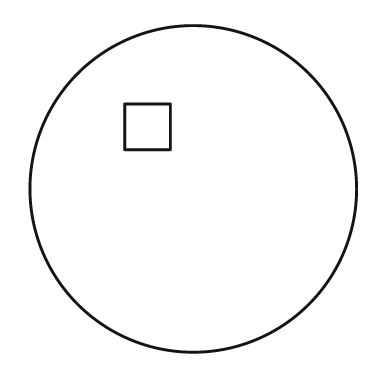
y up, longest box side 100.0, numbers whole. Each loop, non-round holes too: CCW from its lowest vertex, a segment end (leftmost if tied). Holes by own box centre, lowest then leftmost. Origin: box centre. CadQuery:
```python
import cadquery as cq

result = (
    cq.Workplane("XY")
    .moveTo(0.0, 0.0)
    .circle(50.0)
    .moveTo(-21.0, 12.0)
    .lineTo(-7.0, 12.0)
    .lineTo(-7.0, 26.0)
    .lineTo(-21.0, 26.0)
    .close()
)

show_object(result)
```